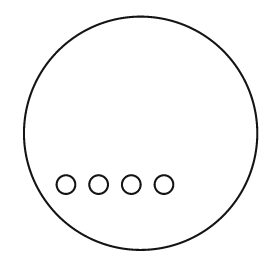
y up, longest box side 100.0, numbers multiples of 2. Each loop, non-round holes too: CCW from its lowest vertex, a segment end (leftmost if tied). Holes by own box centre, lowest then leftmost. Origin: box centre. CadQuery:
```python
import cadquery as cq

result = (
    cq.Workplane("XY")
    .moveTo(0.0, 0.0)
    .circle(50.0)
    .moveTo(-32.0, -22.0)
    .circle(4.0)
    .moveTo(-18.0, -22.0)
    .circle(4.0)
    .moveTo(-4.0, -22.0)
    .circle(4.0)
    .moveTo(10.0, -22.0)
    .circle(4.0)
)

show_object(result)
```